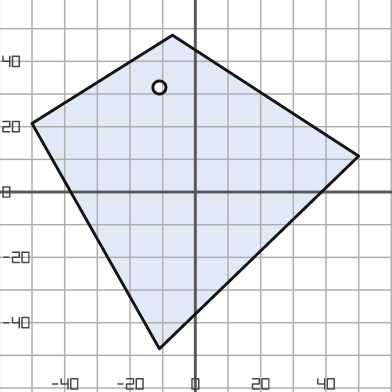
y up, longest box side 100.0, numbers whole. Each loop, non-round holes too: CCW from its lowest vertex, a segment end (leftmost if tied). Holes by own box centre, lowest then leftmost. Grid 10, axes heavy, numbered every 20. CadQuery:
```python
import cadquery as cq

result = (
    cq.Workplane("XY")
    .moveTo(-11.0, -48.0)
    .lineTo(50.0, 11.0)
    .lineTo(-7.0, 48.0)
    .lineTo(-50.0, 21.0)
    .close()
    .moveTo(-11.0, 32.0)
    .circle(2.0)
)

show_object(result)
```